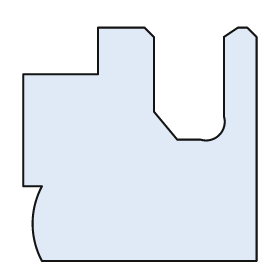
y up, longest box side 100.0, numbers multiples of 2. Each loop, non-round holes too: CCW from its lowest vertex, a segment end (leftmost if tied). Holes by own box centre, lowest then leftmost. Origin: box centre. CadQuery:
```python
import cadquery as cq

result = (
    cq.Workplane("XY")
    .moveTo(-42.0, -50.0)
    .lineTo(50.0, -50.0)
    .lineTo(50.0, 46.0)
    .lineTo(46.0, 50.0)
    .lineTo(42.0, 50.0)
    .lineTo(36.0, 46.0)
    .lineTo(36.0, 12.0)
    .threePointArc((34.0, 4.0), (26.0, 2.0))
    .lineTo(16.0, 2.0)
    .lineTo(6.0, 14.0)
    .lineTo(6.0, 46.0)
    .lineTo(2.0, 50.0)
    .lineTo(-18.0, 50.0)
    .lineTo(-18.0, 30.0)
    .lineTo(-50.0, 30.0)
    .lineTo(-50.0, -18.0)
    .lineTo(-42.0, -18.0)
    .threePointArc((-46.0, -34.0), (-42.0, -50.0))
    .close()
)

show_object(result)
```